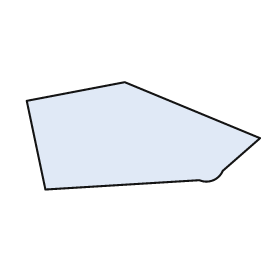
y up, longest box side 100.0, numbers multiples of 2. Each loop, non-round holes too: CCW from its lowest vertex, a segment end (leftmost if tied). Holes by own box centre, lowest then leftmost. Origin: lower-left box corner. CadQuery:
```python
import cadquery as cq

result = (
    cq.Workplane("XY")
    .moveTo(8.0, 0.0)
    .lineTo(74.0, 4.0)
    .threePointArc((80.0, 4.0), (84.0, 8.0))
    .lineTo(100.0, 22.0)
    .lineTo(42.0, 46.0)
    .lineTo(0.0, 38.0)
    .close()
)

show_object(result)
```